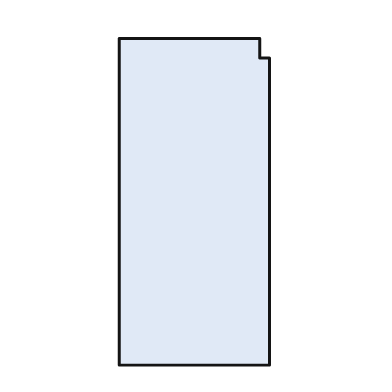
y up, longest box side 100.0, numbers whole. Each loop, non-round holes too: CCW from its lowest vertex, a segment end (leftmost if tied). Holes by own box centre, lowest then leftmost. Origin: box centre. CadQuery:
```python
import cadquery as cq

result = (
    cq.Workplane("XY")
    .moveTo(-23.0, -50.0)
    .lineTo(23.0, -50.0)
    .lineTo(23.0, 44.0)
    .lineTo(20.0, 44.0)
    .lineTo(20.0, 50.0)
    .lineTo(-23.0, 50.0)
    .close()
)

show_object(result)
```